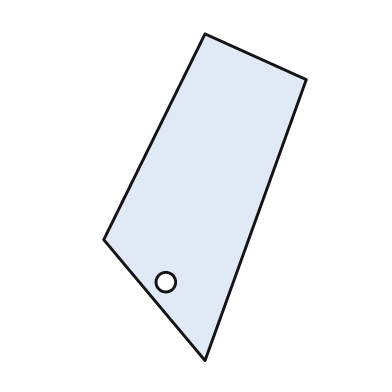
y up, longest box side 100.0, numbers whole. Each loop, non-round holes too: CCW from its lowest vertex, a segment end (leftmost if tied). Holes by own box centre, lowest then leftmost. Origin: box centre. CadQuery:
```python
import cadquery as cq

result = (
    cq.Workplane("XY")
    .moveTo(0.0, -50.0)
    .lineTo(31.0, 36.0)
    .lineTo(0.0, 50.0)
    .lineTo(-31.0, -13.0)
    .close()
    .moveTo(-12.0, -26.0)
    .circle(3.0)
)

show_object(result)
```